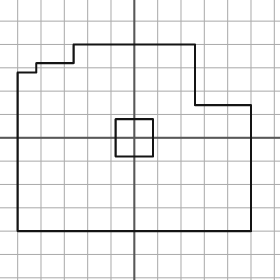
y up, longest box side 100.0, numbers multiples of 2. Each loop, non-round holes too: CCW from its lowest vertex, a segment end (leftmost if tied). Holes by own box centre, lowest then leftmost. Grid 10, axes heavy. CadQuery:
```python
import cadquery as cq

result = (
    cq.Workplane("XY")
    .moveTo(-50.0, -40.0)
    .lineTo(50.0, -40.0)
    .lineTo(50.0, 14.0)
    .lineTo(26.0, 14.0)
    .lineTo(26.0, 40.0)
    .lineTo(-26.0, 40.0)
    .lineTo(-26.0, 32.0)
    .lineTo(-42.0, 32.0)
    .lineTo(-42.0, 28.0)
    .lineTo(-50.0, 28.0)
    .close()
    .moveTo(-8.0, -8.0)
    .lineTo(8.0, -8.0)
    .lineTo(8.0, 8.0)
    .lineTo(-8.0, 8.0)
    .close()
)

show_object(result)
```